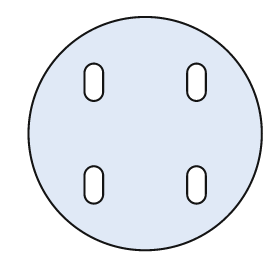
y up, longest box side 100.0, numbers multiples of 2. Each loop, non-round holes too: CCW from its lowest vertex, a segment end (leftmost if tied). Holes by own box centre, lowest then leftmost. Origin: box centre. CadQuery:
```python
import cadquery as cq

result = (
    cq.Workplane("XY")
    .moveTo(0.0, 0.0)
    .circle(50.0)
    .moveTo(-26.0, -26.0)
    .threePointArc((-22.0, -30.0), (-18.0, -26.0))
    .lineTo(-18.0, -18.0)
    .threePointArc((-22.0, -14.0), (-26.0, -18.0))
    .close()
    .moveTo(18.0, -26.0)
    .threePointArc((22.0, -30.0), (26.0, -26.0))
    .lineTo(26.0, -18.0)
    .threePointArc((22.0, -14.0), (18.0, -18.0))
    .close()
    .moveTo(-26.0, 18.0)
    .threePointArc((-22.0, 14.0), (-18.0, 18.0))
    .lineTo(-18.0, 26.0)
    .threePointArc((-22.0, 30.0), (-26.0, 26.0))
    .close()
    .moveTo(18.0, 18.0)
    .threePointArc((22.0, 14.0), (26.0, 18.0))
    .lineTo(26.0, 26.0)
    .threePointArc((22.0, 30.0), (18.0, 26.0))
    .close()
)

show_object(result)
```